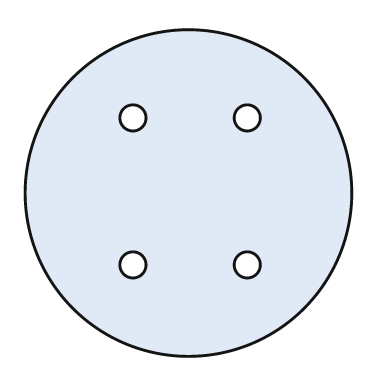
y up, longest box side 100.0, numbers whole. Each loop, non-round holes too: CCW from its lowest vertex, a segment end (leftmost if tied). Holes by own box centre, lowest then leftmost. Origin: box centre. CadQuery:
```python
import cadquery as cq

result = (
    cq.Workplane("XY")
    .moveTo(0.0, 0.0)
    .circle(50.0)
    .moveTo(-17.0, -22.0)
    .circle(4.0)
    .moveTo(18.0, -22.0)
    .circle(4.0)
    .moveTo(-17.0, 23.0)
    .circle(4.0)
    .moveTo(18.0, 23.0)
    .circle(4.0)
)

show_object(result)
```